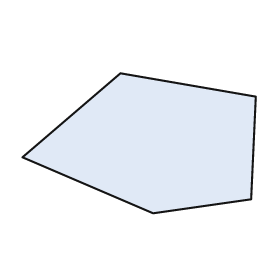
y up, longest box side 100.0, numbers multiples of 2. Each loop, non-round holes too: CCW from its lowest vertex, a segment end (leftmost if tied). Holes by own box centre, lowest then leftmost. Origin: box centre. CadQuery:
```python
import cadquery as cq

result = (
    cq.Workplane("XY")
    .moveTo(6.0, -30.0)
    .lineTo(48.0, -24.0)
    .lineTo(50.0, 20.0)
    .lineTo(-8.0, 30.0)
    .lineTo(-50.0, -6.0)
    .close()
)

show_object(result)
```